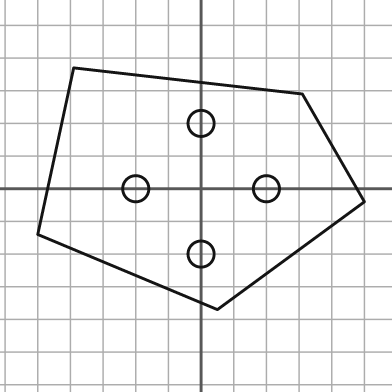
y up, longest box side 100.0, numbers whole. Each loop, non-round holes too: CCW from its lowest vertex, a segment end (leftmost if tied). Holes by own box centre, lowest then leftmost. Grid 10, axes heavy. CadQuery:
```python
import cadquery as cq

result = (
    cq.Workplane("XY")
    .moveTo(5.0, -37.0)
    .lineTo(50.0, -4.0)
    .lineTo(31.0, 29.0)
    .lineTo(-39.0, 37.0)
    .lineTo(-50.0, -14.0)
    .close()
    .moveTo(0.0, -20.0)
    .circle(4.0)
    .moveTo(-20.0, 0.0)
    .circle(4.0)
    .moveTo(20.0, 0.0)
    .circle(4.0)
    .moveTo(0.0, 20.0)
    .circle(4.0)
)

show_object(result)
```